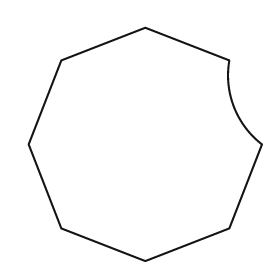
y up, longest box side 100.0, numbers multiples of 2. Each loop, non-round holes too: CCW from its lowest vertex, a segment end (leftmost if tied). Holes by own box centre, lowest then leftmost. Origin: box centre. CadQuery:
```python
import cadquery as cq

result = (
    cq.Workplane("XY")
    .moveTo(0.0, -50.0)
    .lineTo(36.0, -36.0)
    .lineTo(50.0, 0.0)
    .threePointArc((38.0, 16.0), (36.0, 36.0))
    .lineTo(0.0, 50.0)
    .lineTo(-36.0, 36.0)
    .lineTo(-50.0, 0.0)
    .lineTo(-36.0, -36.0)
    .close()
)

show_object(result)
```